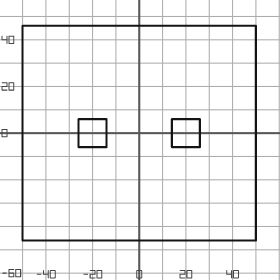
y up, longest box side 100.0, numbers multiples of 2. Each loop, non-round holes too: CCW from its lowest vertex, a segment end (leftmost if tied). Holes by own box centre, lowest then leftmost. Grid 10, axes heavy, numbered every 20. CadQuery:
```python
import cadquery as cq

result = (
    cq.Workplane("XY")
    .moveTo(-50.0, -46.0)
    .lineTo(50.0, -46.0)
    .lineTo(50.0, 46.0)
    .lineTo(-50.0, 46.0)
    .close()
    .moveTo(-26.0, -6.0)
    .lineTo(-14.0, -6.0)
    .lineTo(-14.0, 6.0)
    .lineTo(-26.0, 6.0)
    .close()
    .moveTo(14.0, -6.0)
    .lineTo(26.0, -6.0)
    .lineTo(26.0, 6.0)
    .lineTo(14.0, 6.0)
    .close()
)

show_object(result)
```